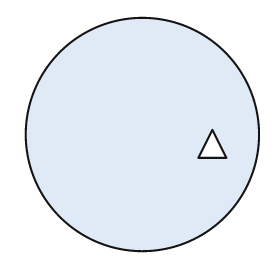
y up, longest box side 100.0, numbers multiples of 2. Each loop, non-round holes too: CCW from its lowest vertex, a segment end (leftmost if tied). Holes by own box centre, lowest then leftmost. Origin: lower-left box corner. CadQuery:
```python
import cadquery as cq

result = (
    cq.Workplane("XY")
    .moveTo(50.0, 50.0)
    .circle(50.0)
    .moveTo(74.0, 40.0)
    .lineTo(86.0, 40.0)
    .lineTo(80.0, 52.0)
    .close()
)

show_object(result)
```